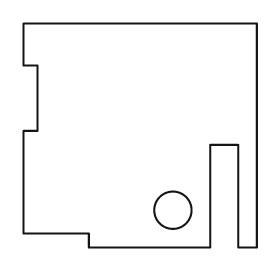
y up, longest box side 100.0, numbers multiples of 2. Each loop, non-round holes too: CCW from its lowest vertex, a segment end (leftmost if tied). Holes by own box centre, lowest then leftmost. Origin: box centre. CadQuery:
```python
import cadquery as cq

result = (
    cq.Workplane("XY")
    .moveTo(-22.0, -48.0)
    .lineTo(30.0, -48.0)
    .lineTo(30.0, -4.0)
    .lineTo(42.0, -4.0)
    .lineTo(42.0, -48.0)
    .lineTo(50.0, -48.0)
    .lineTo(50.0, 48.0)
    .lineTo(-50.0, 48.0)
    .lineTo(-50.0, 30.0)
    .lineTo(-44.0, 30.0)
    .lineTo(-44.0, 2.0)
    .lineTo(-50.0, 2.0)
    .lineTo(-50.0, -42.0)
    .lineTo(-22.0, -42.0)
    .close()
    .moveTo(14.0, -32.0)
    .circle(8.0)
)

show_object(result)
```